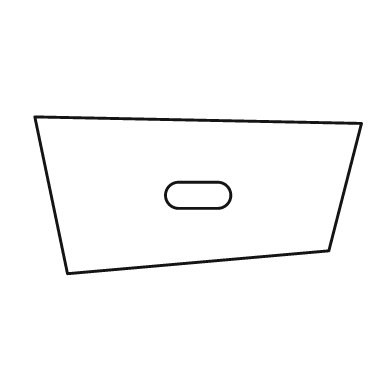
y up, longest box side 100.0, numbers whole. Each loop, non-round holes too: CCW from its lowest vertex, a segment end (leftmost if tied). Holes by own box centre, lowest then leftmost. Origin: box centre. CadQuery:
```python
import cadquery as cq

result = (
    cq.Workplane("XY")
    .moveTo(-40.0, -24.0)
    .lineTo(40.0, -17.0)
    .lineTo(50.0, 22.0)
    .lineTo(-50.0, 24.0)
    .close()
    .moveTo(-6.0, -4.0)
    .lineTo(6.0, -4.0)
    .threePointArc((10.0, 0.0), (6.0, 4.0))
    .lineTo(-6.0, 4.0)
    .threePointArc((-10.0, 0.0), (-6.0, -4.0))
    .close()
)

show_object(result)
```